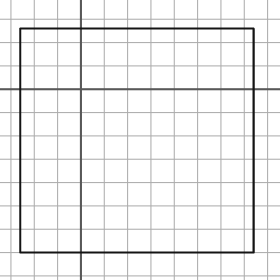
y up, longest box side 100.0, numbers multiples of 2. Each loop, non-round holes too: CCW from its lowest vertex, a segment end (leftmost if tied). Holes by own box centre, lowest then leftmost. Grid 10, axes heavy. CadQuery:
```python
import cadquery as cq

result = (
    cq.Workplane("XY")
    .moveTo(-26.0, -70.0)
    .lineTo(74.0, -70.0)
    .lineTo(74.0, 26.0)
    .lineTo(-26.0, 26.0)
    .close()
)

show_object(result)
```